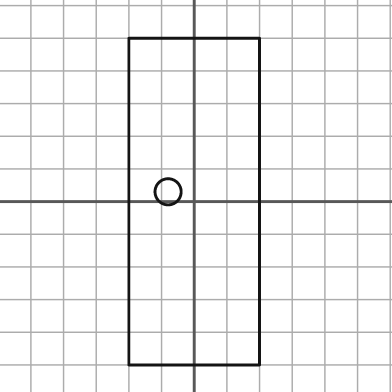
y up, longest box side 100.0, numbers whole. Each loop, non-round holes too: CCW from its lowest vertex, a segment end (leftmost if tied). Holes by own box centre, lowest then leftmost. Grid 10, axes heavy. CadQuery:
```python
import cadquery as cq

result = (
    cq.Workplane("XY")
    .moveTo(-20.0, -50.0)
    .lineTo(20.0, -50.0)
    .lineTo(20.0, 50.0)
    .lineTo(-20.0, 50.0)
    .close()
    .moveTo(-8.0, 3.0)
    .circle(4.0)
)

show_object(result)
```